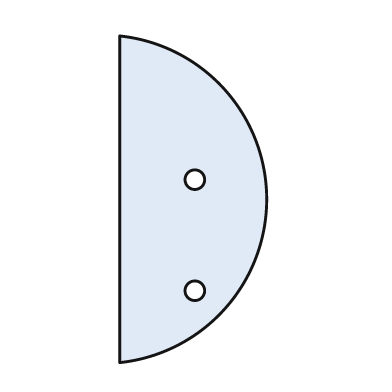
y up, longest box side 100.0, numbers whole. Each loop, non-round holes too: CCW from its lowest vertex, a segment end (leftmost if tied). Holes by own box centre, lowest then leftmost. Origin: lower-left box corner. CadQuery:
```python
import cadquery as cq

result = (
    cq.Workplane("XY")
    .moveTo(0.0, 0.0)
    .threePointArc((45.0, 50.0), (0.0, 100.0))
    .close()
    .moveTo(23.0, 22.0)
    .circle(3.0)
    .moveTo(23.0, 56.0)
    .circle(3.0)
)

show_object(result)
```